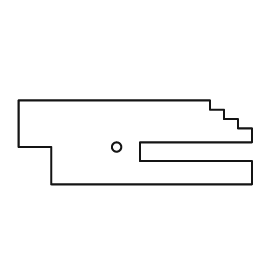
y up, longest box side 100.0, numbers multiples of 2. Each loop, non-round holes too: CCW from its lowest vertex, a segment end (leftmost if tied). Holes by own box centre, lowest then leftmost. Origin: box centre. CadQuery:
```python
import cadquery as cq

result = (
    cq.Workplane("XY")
    .moveTo(-36.0, -18.0)
    .lineTo(50.0, -18.0)
    .lineTo(50.0, -8.0)
    .lineTo(2.0, -8.0)
    .lineTo(2.0, 0.0)
    .lineTo(50.0, 0.0)
    .lineTo(50.0, 6.0)
    .lineTo(44.0, 6.0)
    .lineTo(44.0, 10.0)
    .lineTo(38.0, 10.0)
    .lineTo(38.0, 14.0)
    .lineTo(32.0, 14.0)
    .lineTo(32.0, 18.0)
    .lineTo(-50.0, 18.0)
    .lineTo(-50.0, -2.0)
    .lineTo(-36.0, -2.0)
    .close()
    .moveTo(-8.0, -2.0)
    .circle(2.0)
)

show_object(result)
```